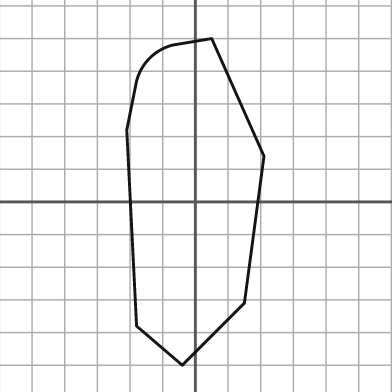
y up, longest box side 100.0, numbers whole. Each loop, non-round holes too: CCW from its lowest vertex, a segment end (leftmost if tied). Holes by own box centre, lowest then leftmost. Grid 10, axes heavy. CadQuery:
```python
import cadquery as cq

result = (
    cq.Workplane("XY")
    .moveTo(-4.0, -50.0)
    .lineTo(15.0, -31.0)
    .lineTo(21.0, 14.0)
    .lineTo(5.0, 50.0)
    .lineTo(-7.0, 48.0)
    .threePointArc((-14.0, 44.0), (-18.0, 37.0))
    .lineTo(-21.0, 22.0)
    .lineTo(-18.0, -38.0)
    .close()
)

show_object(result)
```